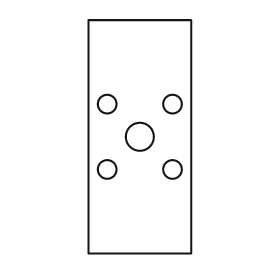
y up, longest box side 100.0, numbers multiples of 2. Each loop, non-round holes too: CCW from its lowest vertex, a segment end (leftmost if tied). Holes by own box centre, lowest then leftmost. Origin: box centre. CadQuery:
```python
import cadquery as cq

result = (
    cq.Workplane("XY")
    .moveTo(-22.0, -50.0)
    .lineTo(22.0, -50.0)
    .lineTo(22.0, 50.0)
    .lineTo(-22.0, 50.0)
    .close()
    .moveTo(-14.0, -14.0)
    .circle(4.0)
    .moveTo(14.0, -14.0)
    .circle(4.0)
    .moveTo(0.0, 0.0)
    .circle(6.0)
    .moveTo(-14.0, 14.0)
    .circle(4.0)
    .moveTo(14.0, 14.0)
    .circle(4.0)
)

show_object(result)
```